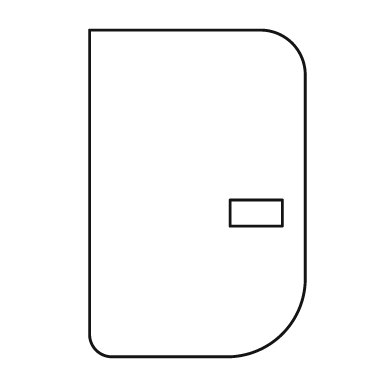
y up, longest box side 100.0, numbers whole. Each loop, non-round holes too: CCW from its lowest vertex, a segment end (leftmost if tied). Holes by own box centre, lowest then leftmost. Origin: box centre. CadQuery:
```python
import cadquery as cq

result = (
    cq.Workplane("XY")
    .moveTo(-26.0, -50.0)
    .lineTo(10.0, -50.0)
    .threePointArc((26.0, -43.0), (33.0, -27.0))
    .lineTo(33.0, 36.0)
    .threePointArc((29.0, 46.0), (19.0, 50.0))
    .lineTo(-33.0, 50.0)
    .lineTo(-33.0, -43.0)
    .threePointArc((-31.0, -48.0), (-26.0, -50.0))
    .close()
    .moveTo(10.0, -10.0)
    .lineTo(26.0, -10.0)
    .lineTo(26.0, -2.0)
    .lineTo(10.0, -2.0)
    .close()
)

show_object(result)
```